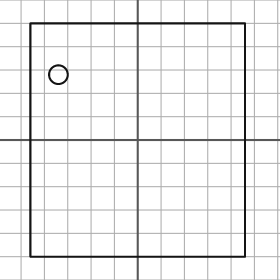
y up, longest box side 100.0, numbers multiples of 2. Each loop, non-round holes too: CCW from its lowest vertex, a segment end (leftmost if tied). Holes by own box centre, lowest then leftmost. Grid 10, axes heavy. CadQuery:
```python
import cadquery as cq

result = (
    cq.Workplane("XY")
    .moveTo(-46.0, -50.0)
    .lineTo(46.0, -50.0)
    .lineTo(46.0, 50.0)
    .lineTo(-46.0, 50.0)
    .close()
    .moveTo(-34.0, 28.0)
    .circle(4.0)
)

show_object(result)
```